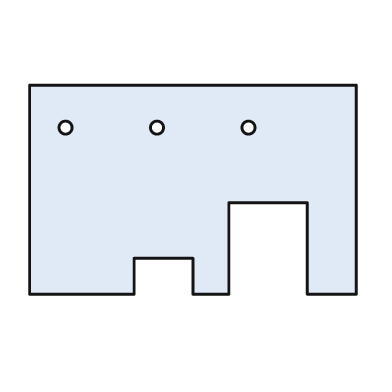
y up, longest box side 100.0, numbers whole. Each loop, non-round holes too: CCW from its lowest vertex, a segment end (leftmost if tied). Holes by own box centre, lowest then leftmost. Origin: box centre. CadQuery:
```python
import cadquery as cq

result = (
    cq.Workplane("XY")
    .moveTo(-50.0, -32.0)
    .lineTo(-18.0, -32.0)
    .lineTo(-18.0, -21.0)
    .lineTo(0.0, -21.0)
    .lineTo(0.0, -32.0)
    .lineTo(11.0, -32.0)
    .lineTo(11.0, -4.0)
    .lineTo(35.0, -4.0)
    .lineTo(35.0, -32.0)
    .lineTo(50.0, -32.0)
    .lineTo(50.0, 32.0)
    .lineTo(-50.0, 32.0)
    .close()
    .moveTo(-39.0, 19.0)
    .circle(2.0)
    .moveTo(-11.0, 19.0)
    .circle(2.0)
    .moveTo(17.0, 19.0)
    .circle(2.0)
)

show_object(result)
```